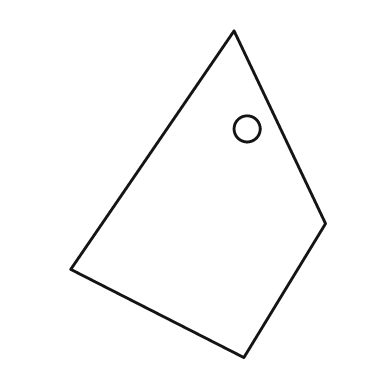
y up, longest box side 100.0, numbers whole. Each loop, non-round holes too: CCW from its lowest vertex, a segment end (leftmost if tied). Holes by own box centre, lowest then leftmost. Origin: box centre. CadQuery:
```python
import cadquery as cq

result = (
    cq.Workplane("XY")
    .moveTo(14.0, -50.0)
    .lineTo(39.0, -9.0)
    .lineTo(11.0, 50.0)
    .lineTo(-39.0, -23.0)
    .close()
    .moveTo(15.0, 20.0)
    .circle(4.0)
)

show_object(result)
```